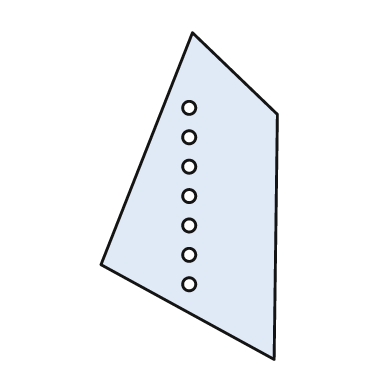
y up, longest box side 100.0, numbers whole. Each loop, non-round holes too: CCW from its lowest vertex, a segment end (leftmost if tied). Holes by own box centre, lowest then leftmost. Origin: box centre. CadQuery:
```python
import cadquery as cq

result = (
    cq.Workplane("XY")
    .moveTo(26.0, -50.0)
    .lineTo(27.0, 25.0)
    .lineTo(1.0, 50.0)
    .lineTo(-27.0, -21.0)
    .close()
    .moveTo(0.0, -27.0)
    .circle(2.0)
    .moveTo(0.0, -18.0)
    .circle(2.0)
    .moveTo(0.0, -9.0)
    .circle(2.0)
    .moveTo(0.0, 0.0)
    .circle(2.0)
    .moveTo(0.0, 9.0)
    .circle(2.0)
    .moveTo(0.0, 18.0)
    .circle(2.0)
    .moveTo(0.0, 27.0)
    .circle(2.0)
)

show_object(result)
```